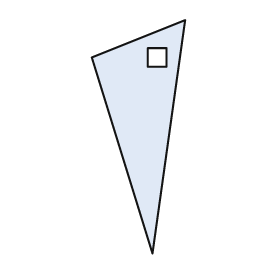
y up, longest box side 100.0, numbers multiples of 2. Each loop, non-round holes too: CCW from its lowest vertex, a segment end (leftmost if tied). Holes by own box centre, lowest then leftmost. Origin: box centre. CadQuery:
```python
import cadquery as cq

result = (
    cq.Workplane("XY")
    .moveTo(6.0, -50.0)
    .lineTo(20.0, 50.0)
    .lineTo(-20.0, 34.0)
    .close()
    .moveTo(4.0, 30.0)
    .lineTo(12.0, 30.0)
    .lineTo(12.0, 38.0)
    .lineTo(4.0, 38.0)
    .close()
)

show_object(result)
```